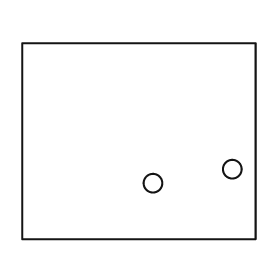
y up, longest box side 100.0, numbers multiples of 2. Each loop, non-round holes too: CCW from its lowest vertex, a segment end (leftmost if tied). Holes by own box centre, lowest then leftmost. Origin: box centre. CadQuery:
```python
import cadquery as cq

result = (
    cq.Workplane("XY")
    .moveTo(-50.0, -42.0)
    .lineTo(50.0, -42.0)
    .lineTo(50.0, 42.0)
    .lineTo(-50.0, 42.0)
    .close()
    .moveTo(6.0, -18.0)
    .circle(4.0)
    .moveTo(40.0, -12.0)
    .circle(4.0)
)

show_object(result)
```